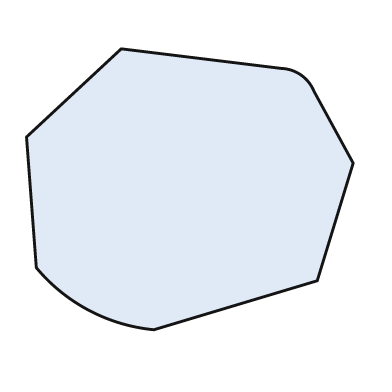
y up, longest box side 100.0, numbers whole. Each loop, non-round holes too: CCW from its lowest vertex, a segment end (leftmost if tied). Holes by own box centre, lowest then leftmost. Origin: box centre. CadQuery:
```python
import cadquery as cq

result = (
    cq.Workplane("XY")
    .moveTo(-11.0, -43.0)
    .lineTo(39.0, -28.0)
    .lineTo(50.0, 8.0)
    .lineTo(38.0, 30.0)
    .threePointArc((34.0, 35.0), (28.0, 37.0))
    .lineTo(-21.0, 43.0)
    .lineTo(-50.0, 16.0)
    .lineTo(-47.0, -24.0)
    .threePointArc((-31.0, -37.0), (-11.0, -43.0))
    .close()
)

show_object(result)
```